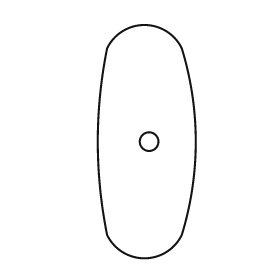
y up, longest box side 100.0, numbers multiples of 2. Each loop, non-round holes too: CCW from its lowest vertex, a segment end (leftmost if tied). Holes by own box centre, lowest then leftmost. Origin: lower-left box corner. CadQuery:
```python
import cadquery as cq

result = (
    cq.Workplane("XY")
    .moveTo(4.0, 10.0)
    .threePointArc((20.0, 0.0), (36.0, 10.0))
    .threePointArc((42.0, 50.0), (36.0, 90.0))
    .threePointArc((20.0, 100.0), (4.0, 90.0))
    .threePointArc((0.0, 50.0), (4.0, 10.0))
    .close()
    .moveTo(22.0, 50.0)
    .circle(4.0)
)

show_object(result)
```